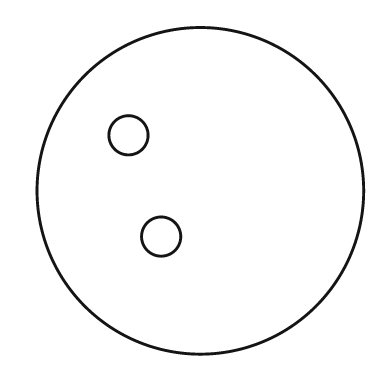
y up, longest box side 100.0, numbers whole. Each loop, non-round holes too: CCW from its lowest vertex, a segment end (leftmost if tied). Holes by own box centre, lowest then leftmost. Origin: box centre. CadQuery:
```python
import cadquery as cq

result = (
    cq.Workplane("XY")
    .moveTo(0.0, 0.0)
    .circle(50.0)
    .moveTo(-12.0, -14.0)
    .circle(6.0)
    .moveTo(-22.0, 17.0)
    .circle(6.0)
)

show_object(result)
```